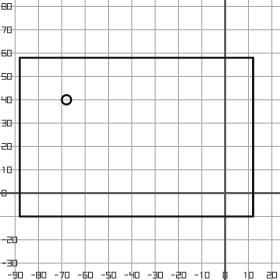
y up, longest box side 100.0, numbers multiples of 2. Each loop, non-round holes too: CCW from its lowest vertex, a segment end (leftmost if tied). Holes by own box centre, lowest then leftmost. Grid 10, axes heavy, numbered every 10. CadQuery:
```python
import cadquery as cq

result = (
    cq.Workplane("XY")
    .moveTo(-88.0, -10.0)
    .lineTo(12.0, -10.0)
    .lineTo(12.0, 58.0)
    .lineTo(-88.0, 58.0)
    .close()
    .moveTo(-68.0, 40.0)
    .circle(2.0)
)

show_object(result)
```